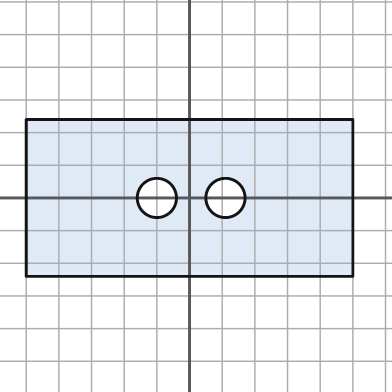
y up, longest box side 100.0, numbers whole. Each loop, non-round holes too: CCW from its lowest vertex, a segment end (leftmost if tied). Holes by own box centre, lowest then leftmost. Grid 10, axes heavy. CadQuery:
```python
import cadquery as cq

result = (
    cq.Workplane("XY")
    .moveTo(-50.0, -24.0)
    .lineTo(50.0, -24.0)
    .lineTo(50.0, 24.0)
    .lineTo(-50.0, 24.0)
    .close()
    .moveTo(-10.0, 0.0)
    .circle(6.0)
    .moveTo(11.0, 0.0)
    .circle(6.0)
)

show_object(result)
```